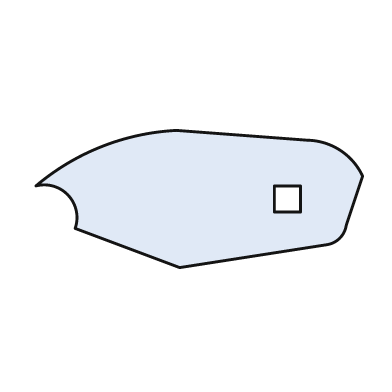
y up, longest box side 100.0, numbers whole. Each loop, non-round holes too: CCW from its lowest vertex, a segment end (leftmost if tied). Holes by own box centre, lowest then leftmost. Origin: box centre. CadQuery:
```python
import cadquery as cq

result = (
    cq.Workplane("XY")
    .moveTo(-6.0, -21.0)
    .lineTo(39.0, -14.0)
    .threePointArc((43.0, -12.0), (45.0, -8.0))
    .lineTo(50.0, 7.0)
    .threePointArc((43.0, 15.0), (33.0, 18.0))
    .lineTo(-7.0, 21.0)
    .threePointArc((-30.0, 16.0), (-50.0, 4.0))
    .threePointArc((-40.0, 1.0), (-38.0, -9.0))
    .close()
    .moveTo(23.0, -4.0)
    .lineTo(31.0, -4.0)
    .lineTo(31.0, 4.0)
    .lineTo(23.0, 4.0)
    .close()
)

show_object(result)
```